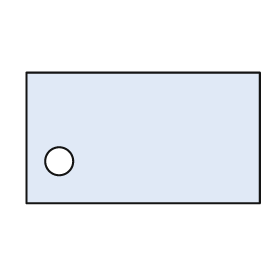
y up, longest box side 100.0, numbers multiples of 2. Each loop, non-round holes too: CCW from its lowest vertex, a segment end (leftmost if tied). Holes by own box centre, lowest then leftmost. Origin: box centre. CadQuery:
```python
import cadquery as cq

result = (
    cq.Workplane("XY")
    .moveTo(-50.0, -28.0)
    .lineTo(50.0, -28.0)
    .lineTo(50.0, 28.0)
    .lineTo(-50.0, 28.0)
    .close()
    .moveTo(-36.0, -10.0)
    .circle(6.0)
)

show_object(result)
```